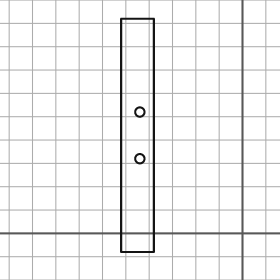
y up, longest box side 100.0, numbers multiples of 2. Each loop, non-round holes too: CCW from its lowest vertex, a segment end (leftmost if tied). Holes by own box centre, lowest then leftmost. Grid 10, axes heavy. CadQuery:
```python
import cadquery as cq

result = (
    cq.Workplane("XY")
    .moveTo(-52.0, -8.0)
    .lineTo(-38.0, -8.0)
    .lineTo(-38.0, 92.0)
    .lineTo(-52.0, 92.0)
    .close()
    .moveTo(-44.0, 32.0)
    .circle(2.0)
    .moveTo(-44.0, 52.0)
    .circle(2.0)
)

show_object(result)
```